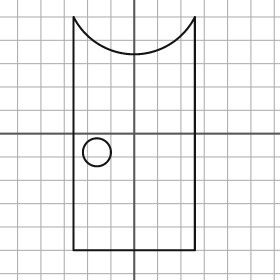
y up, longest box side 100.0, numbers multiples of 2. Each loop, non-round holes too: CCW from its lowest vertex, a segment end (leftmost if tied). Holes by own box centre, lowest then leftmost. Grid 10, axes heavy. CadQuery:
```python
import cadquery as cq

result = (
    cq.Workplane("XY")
    .moveTo(-26.0, -50.0)
    .lineTo(26.0, -50.0)
    .lineTo(26.0, 50.0)
    .threePointArc((0.0, 34.0), (-26.0, 50.0))
    .close()
    .moveTo(-16.0, -8.0)
    .circle(6.0)
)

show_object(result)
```